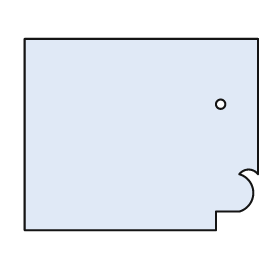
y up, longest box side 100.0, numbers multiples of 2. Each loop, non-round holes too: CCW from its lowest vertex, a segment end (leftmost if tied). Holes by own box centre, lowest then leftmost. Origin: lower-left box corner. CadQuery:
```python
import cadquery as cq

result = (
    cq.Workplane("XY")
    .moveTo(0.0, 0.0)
    .lineTo(82.0, 0.0)
    .lineTo(82.0, 8.0)
    .lineTo(92.0, 8.0)
    .threePointArc((98.0, 16.0), (92.0, 24.0))
    .threePointArc((96.0, 26.0), (100.0, 24.0))
    .lineTo(100.0, 82.0)
    .lineTo(0.0, 82.0)
    .close()
    .moveTo(84.0, 54.0)
    .circle(2.0)
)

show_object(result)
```